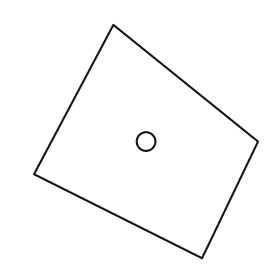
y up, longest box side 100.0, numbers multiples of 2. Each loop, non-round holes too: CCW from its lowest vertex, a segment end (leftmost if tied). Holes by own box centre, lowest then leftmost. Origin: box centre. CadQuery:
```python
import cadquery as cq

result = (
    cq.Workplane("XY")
    .moveTo(24.0, -50.0)
    .lineTo(48.0, 0.0)
    .lineTo(-14.0, 50.0)
    .lineTo(-48.0, -14.0)
    .close()
    .moveTo(0.0, 0.0)
    .circle(4.0)
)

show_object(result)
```